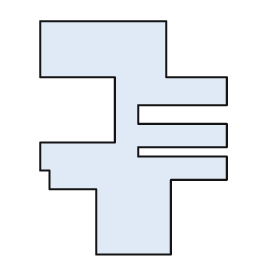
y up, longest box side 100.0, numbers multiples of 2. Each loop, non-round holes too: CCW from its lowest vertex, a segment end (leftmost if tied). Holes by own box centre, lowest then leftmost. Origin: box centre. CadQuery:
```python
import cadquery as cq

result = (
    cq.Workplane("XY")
    .moveTo(-16.0, -50.0)
    .lineTo(16.0, -50.0)
    .lineTo(16.0, -18.0)
    .lineTo(40.0, -18.0)
    .lineTo(40.0, -8.0)
    .lineTo(2.0, -8.0)
    .lineTo(2.0, -4.0)
    .lineTo(40.0, -4.0)
    .lineTo(40.0, 6.0)
    .lineTo(2.0, 6.0)
    .lineTo(2.0, 14.0)
    .lineTo(40.0, 14.0)
    .lineTo(40.0, 26.0)
    .lineTo(14.0, 26.0)
    .lineTo(14.0, 50.0)
    .lineTo(-40.0, 50.0)
    .lineTo(-40.0, 26.0)
    .lineTo(-8.0, 26.0)
    .lineTo(-8.0, -2.0)
    .lineTo(-40.0, -2.0)
    .lineTo(-40.0, -14.0)
    .lineTo(-36.0, -14.0)
    .lineTo(-36.0, -22.0)
    .lineTo(-16.0, -22.0)
    .close()
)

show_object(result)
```